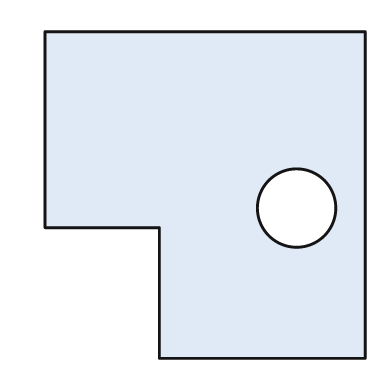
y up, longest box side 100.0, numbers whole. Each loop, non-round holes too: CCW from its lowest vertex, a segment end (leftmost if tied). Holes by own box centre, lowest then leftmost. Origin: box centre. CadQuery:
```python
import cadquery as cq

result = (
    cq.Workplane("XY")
    .moveTo(-14.0, -50.0)
    .lineTo(49.0, -50.0)
    .lineTo(49.0, 50.0)
    .lineTo(-49.0, 50.0)
    .lineTo(-49.0, -10.0)
    .lineTo(-14.0, -10.0)
    .close()
    .moveTo(28.0, -4.0)
    .circle(12.0)
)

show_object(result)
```